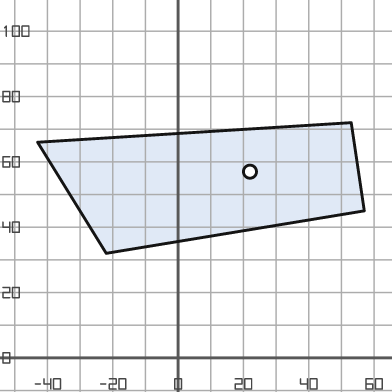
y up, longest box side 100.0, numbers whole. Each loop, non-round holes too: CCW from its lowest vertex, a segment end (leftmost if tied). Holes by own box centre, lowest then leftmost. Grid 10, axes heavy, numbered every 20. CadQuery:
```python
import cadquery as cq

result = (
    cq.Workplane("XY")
    .moveTo(-22.0, 32.0)
    .lineTo(57.0, 45.0)
    .lineTo(53.0, 72.0)
    .lineTo(-43.0, 66.0)
    .close()
    .moveTo(22.0, 57.0)
    .circle(2.0)
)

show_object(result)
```